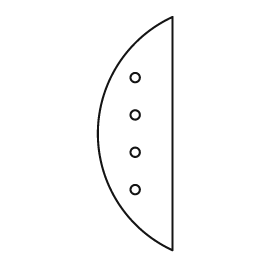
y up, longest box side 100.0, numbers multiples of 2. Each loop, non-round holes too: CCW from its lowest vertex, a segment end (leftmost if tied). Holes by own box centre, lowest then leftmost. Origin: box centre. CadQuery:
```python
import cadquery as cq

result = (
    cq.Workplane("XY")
    .moveTo(16.0, -50.0)
    .lineTo(16.0, 50.0)
    .threePointArc((-16.0, 0.0), (16.0, -50.0))
    .close()
    .moveTo(0.0, -24.0)
    .circle(2.0)
    .moveTo(0.0, -8.0)
    .circle(2.0)
    .moveTo(0.0, 8.0)
    .circle(2.0)
    .moveTo(0.0, 24.0)
    .circle(2.0)
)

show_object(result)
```